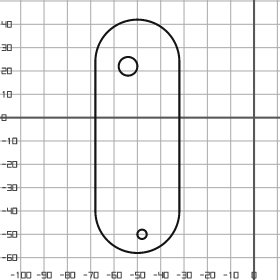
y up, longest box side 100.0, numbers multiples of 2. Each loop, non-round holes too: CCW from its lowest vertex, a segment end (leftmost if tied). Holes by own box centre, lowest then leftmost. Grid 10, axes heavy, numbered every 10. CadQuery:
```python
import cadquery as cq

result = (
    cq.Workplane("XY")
    .moveTo(-68.0, -40.0)
    .threePointArc((-50.0, -58.0), (-32.0, -40.0))
    .lineTo(-32.0, 24.0)
    .threePointArc((-50.0, 42.0), (-68.0, 24.0))
    .close()
    .moveTo(-48.0, -50.0)
    .circle(2.0)
    .moveTo(-54.0, 22.0)
    .circle(4.0)
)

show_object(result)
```